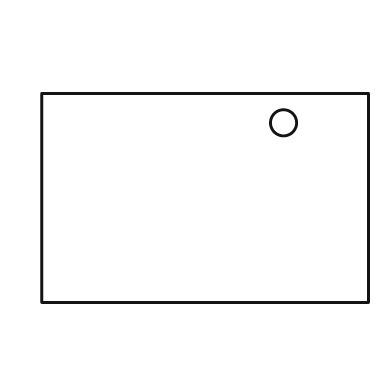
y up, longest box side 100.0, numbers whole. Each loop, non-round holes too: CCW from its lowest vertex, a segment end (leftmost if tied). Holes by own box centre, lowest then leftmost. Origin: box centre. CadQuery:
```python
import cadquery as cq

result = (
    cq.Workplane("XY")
    .moveTo(-50.0, -32.0)
    .lineTo(50.0, -32.0)
    .lineTo(50.0, 32.0)
    .lineTo(-50.0, 32.0)
    .close()
    .moveTo(24.0, 23.0)
    .circle(4.0)
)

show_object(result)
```